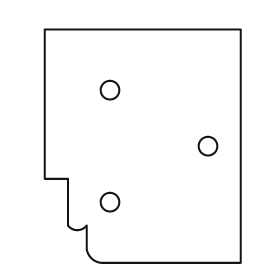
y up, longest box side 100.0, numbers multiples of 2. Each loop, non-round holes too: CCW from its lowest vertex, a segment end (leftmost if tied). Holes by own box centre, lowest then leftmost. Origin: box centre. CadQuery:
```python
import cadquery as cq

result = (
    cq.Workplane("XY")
    .moveTo(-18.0, -50.0)
    .lineTo(42.0, -50.0)
    .lineTo(42.0, 50.0)
    .lineTo(-42.0, 50.0)
    .lineTo(-42.0, -14.0)
    .lineTo(-32.0, -14.0)
    .lineTo(-32.0, -34.0)
    .threePointArc((-28.0, -36.0), (-24.0, -34.0))
    .lineTo(-24.0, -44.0)
    .threePointArc((-22.0, -48.0), (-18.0, -50.0))
    .close()
    .moveTo(-14.0, -24.0)
    .circle(4.0)
    .moveTo(28.0, 0.0)
    .circle(4.0)
    .moveTo(-14.0, 24.0)
    .circle(4.0)
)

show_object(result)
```